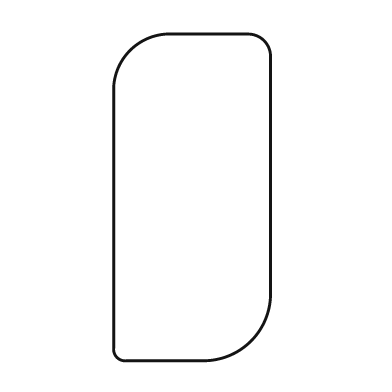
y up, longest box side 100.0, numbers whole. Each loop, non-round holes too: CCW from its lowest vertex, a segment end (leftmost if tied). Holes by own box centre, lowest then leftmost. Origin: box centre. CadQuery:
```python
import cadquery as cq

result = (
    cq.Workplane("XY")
    .moveTo(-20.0, -50.0)
    .lineTo(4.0, -50.0)
    .threePointArc((18.0, -44.0), (24.0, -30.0))
    .lineTo(24.0, 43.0)
    .threePointArc((22.0, 48.0), (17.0, 50.0))
    .lineTo(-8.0, 50.0)
    .threePointArc((-19.0, 45.0), (-24.0, 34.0))
    .lineTo(-24.0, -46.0)
    .threePointArc((-23.0, -49.0), (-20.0, -50.0))
    .close()
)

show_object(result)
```